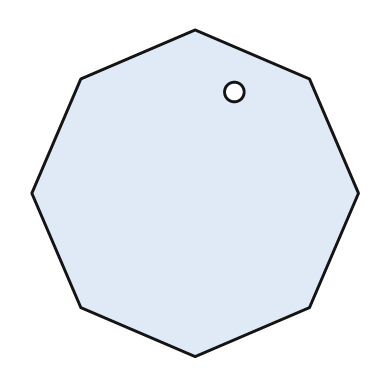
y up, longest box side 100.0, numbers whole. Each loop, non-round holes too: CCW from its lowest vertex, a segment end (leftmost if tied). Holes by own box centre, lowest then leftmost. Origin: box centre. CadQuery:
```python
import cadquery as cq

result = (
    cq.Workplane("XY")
    .moveTo(0.0, -50.0)
    .lineTo(35.0, -35.0)
    .lineTo(50.0, 0.0)
    .lineTo(35.0, 35.0)
    .lineTo(0.0, 50.0)
    .lineTo(-35.0, 35.0)
    .lineTo(-50.0, 0.0)
    .lineTo(-35.0, -35.0)
    .close()
    .moveTo(12.0, 31.0)
    .circle(3.0)
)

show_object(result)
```